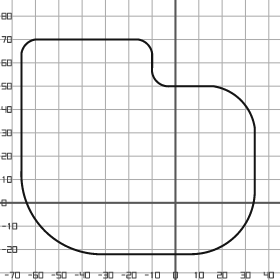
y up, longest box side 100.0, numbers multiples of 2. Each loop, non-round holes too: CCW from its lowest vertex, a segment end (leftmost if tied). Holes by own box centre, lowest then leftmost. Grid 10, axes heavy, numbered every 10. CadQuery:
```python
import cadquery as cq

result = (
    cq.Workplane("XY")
    .moveTo(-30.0, -22.0)
    .lineTo(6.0, -22.0)
    .threePointArc((26.0, -14.0), (34.0, 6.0))
    .lineTo(34.0, 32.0)
    .threePointArc((28.0, 44.0), (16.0, 50.0))
    .lineTo(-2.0, 50.0)
    .threePointArc((-8.0, 52.0), (-10.0, 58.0))
    .lineTo(-10.0, 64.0)
    .threePointArc((-12.0, 68.0), (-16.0, 70.0))
    .lineTo(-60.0, 70.0)
    .threePointArc((-64.0, 68.0), (-66.0, 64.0))
    .lineTo(-66.0, 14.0)
    .threePointArc((-56.0, -12.0), (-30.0, -22.0))
    .close()
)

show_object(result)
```